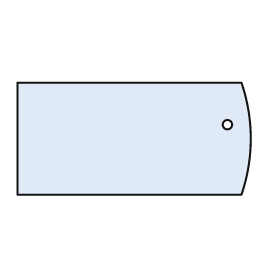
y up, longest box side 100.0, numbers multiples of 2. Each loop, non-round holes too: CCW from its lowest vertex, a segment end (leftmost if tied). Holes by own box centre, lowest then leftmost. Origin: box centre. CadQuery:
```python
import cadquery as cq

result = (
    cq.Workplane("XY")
    .moveTo(-50.0, -24.0)
    .lineTo(46.0, -24.0)
    .threePointArc((50.0, 0.0), (46.0, 24.0))
    .lineTo(-50.0, 24.0)
    .close()
    .moveTo(40.0, 6.0)
    .circle(2.0)
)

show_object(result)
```